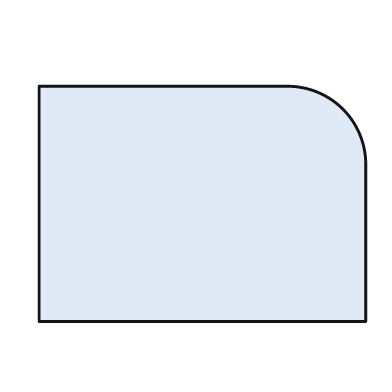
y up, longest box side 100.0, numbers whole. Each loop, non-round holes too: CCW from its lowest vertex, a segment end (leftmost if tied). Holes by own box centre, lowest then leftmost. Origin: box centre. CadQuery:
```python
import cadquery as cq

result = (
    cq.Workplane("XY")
    .moveTo(-50.0, -36.0)
    .lineTo(50.0, -36.0)
    .lineTo(50.0, 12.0)
    .threePointArc((43.0, 29.0), (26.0, 36.0))
    .lineTo(-50.0, 36.0)
    .close()
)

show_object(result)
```